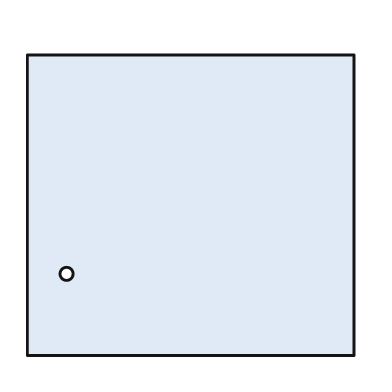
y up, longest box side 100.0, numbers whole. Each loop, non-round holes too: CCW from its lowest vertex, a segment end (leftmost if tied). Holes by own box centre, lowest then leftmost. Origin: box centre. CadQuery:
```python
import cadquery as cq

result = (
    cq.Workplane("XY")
    .moveTo(-50.0, -46.0)
    .lineTo(50.0, -46.0)
    .lineTo(50.0, 46.0)
    .lineTo(-50.0, 46.0)
    .close()
    .moveTo(-38.0, -21.0)
    .circle(2.0)
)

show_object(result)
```